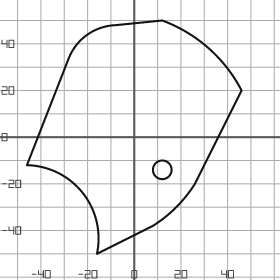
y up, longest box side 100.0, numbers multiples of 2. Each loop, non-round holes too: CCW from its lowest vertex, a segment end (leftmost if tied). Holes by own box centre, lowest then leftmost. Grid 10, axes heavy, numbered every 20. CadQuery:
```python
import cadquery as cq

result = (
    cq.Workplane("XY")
    .moveTo(-16.0, -50.0)
    .lineTo(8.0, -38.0)
    .threePointArc((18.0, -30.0), (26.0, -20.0))
    .lineTo(46.0, 20.0)
    .threePointArc((32.0, 38.0), (12.0, 50.0))
    .lineTo(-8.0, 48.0)
    .threePointArc((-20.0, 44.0), (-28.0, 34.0))
    .lineTo(-46.0, -12.0)
    .threePointArc((-22.0, -24.0), (-16.0, -50.0))
    .close()
    .moveTo(12.0, -14.0)
    .circle(4.0)
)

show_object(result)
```